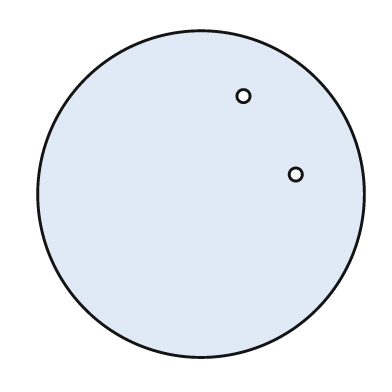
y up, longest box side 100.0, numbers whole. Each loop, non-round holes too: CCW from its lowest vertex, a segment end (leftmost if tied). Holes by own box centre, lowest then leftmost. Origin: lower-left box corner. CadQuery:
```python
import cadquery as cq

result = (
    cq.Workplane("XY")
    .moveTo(50.0, 50.0)
    .circle(50.0)
    .moveTo(79.0, 56.0)
    .circle(2.0)
    .moveTo(63.0, 80.0)
    .circle(2.0)
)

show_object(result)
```